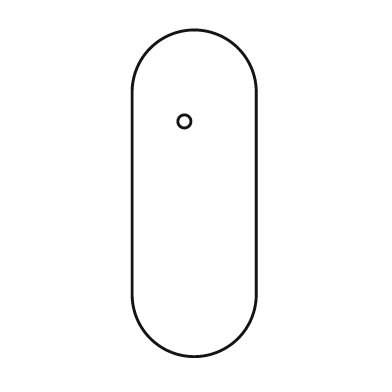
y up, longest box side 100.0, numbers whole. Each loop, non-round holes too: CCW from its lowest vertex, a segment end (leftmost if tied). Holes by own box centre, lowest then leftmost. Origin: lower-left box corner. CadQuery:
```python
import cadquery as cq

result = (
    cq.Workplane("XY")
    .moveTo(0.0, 19.0)
    .threePointArc((19.0, 0.0), (38.0, 19.0))
    .lineTo(38.0, 81.0)
    .threePointArc((19.0, 100.0), (0.0, 81.0))
    .close()
    .moveTo(16.0, 72.0)
    .circle(2.0)
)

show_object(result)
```